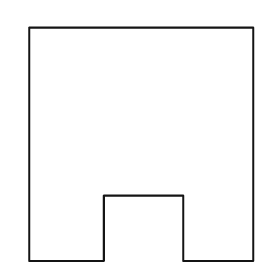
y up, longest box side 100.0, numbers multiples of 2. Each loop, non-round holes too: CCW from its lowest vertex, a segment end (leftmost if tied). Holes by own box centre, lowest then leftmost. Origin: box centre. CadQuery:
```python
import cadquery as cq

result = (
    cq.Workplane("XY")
    .moveTo(-48.0, -50.0)
    .lineTo(-16.0, -50.0)
    .lineTo(-16.0, -22.0)
    .lineTo(18.0, -22.0)
    .lineTo(18.0, -50.0)
    .lineTo(48.0, -50.0)
    .lineTo(48.0, 50.0)
    .lineTo(-48.0, 50.0)
    .close()
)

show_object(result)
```